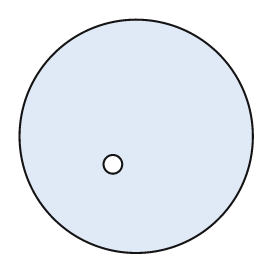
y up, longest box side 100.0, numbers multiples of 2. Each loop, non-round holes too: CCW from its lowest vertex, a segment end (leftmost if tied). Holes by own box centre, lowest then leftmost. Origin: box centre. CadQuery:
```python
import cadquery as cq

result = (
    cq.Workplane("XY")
    .moveTo(0.0, 0.0)
    .circle(50.0)
    .moveTo(-10.0, -12.0)
    .circle(4.0)
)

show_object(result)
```